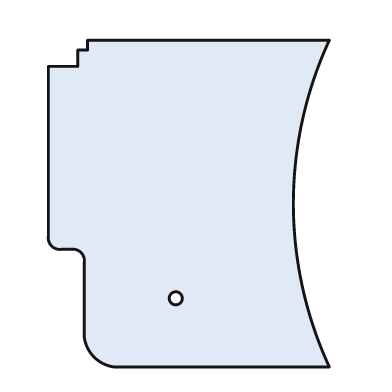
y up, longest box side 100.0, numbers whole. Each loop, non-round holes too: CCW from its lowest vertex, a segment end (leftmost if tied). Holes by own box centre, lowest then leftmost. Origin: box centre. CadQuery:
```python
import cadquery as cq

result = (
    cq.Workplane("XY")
    .moveTo(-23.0, -50.0)
    .lineTo(43.0, -50.0)
    .threePointArc((32.0, 0.0), (43.0, 50.0))
    .lineTo(-31.0, 50.0)
    .lineTo(-31.0, 47.0)
    .lineTo(-34.0, 47.0)
    .lineTo(-34.0, 42.0)
    .lineTo(-43.0, 42.0)
    .lineTo(-43.0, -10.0)
    .threePointArc((-42.0, -13.0), (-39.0, -14.0))
    .lineTo(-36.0, -14.0)
    .threePointArc((-33.0, -15.0), (-32.0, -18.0))
    .lineTo(-32.0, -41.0)
    .threePointArc((-29.0, -47.0), (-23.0, -50.0))
    .close()
    .moveTo(-4.0, -29.0)
    .circle(2.0)
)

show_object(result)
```